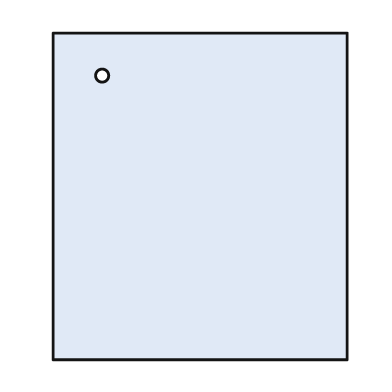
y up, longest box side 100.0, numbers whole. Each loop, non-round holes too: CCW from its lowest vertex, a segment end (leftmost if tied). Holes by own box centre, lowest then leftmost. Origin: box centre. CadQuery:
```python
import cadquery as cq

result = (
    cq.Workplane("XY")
    .moveTo(-45.0, -50.0)
    .lineTo(45.0, -50.0)
    .lineTo(45.0, 50.0)
    .lineTo(-45.0, 50.0)
    .close()
    .moveTo(-30.0, 37.0)
    .circle(2.0)
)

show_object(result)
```